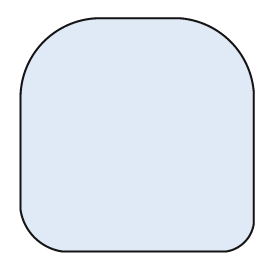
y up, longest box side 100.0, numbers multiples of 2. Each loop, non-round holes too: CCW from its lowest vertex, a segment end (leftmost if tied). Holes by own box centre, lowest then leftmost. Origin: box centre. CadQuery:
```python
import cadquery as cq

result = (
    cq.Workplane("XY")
    .moveTo(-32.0, -50.0)
    .lineTo(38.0, -50.0)
    .threePointArc((46.0, -46.0), (50.0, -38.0))
    .lineTo(50.0, 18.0)
    .threePointArc((40.0, 40.0), (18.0, 50.0))
    .lineTo(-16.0, 50.0)
    .threePointArc((-40.0, 40.0), (-50.0, 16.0))
    .lineTo(-50.0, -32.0)
    .threePointArc((-44.0, -44.0), (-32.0, -50.0))
    .close()
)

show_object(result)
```